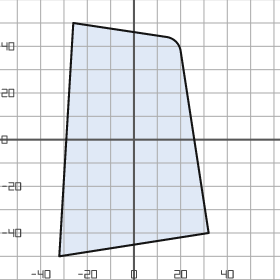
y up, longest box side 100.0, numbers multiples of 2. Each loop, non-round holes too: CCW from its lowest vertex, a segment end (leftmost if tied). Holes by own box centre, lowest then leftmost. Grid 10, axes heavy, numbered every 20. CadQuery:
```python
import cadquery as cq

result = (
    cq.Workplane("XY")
    .moveTo(-32.0, -50.0)
    .lineTo(32.0, -40.0)
    .lineTo(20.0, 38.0)
    .threePointArc((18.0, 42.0), (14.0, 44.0))
    .lineTo(-26.0, 50.0)
    .close()
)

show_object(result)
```